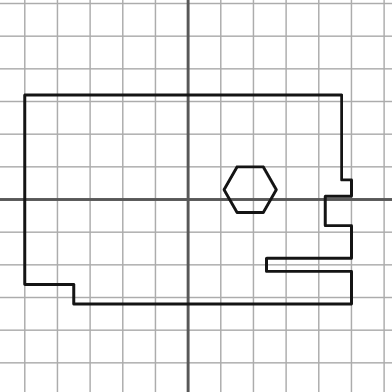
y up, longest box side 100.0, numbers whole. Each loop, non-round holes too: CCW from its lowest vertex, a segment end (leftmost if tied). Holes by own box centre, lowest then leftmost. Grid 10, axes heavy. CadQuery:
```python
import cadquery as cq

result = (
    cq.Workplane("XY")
    .moveTo(-35.0, -32.0)
    .lineTo(50.0, -32.0)
    .lineTo(50.0, -22.0)
    .lineTo(24.0, -22.0)
    .lineTo(24.0, -18.0)
    .lineTo(50.0, -18.0)
    .lineTo(50.0, -8.0)
    .lineTo(42.0, -8.0)
    .lineTo(42.0, 1.0)
    .lineTo(50.0, 1.0)
    .lineTo(50.0, 6.0)
    .lineTo(47.0, 6.0)
    .lineTo(47.0, 32.0)
    .lineTo(-50.0, 32.0)
    .lineTo(-50.0, -26.0)
    .lineTo(-35.0, -26.0)
    .close()
    .moveTo(15.0, -4.0)
    .lineTo(23.0, -4.0)
    .lineTo(27.0, 3.0)
    .lineTo(23.0, 10.0)
    .lineTo(15.0, 10.0)
    .lineTo(11.0, 3.0)
    .close()
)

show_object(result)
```